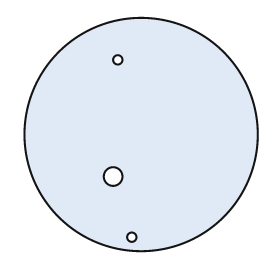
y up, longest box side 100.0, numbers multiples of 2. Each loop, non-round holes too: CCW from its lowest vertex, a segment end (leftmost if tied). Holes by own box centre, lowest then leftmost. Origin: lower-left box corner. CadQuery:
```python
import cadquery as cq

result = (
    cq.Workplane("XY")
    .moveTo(50.0, 50.0)
    .circle(50.0)
    .moveTo(46.0, 6.0)
    .circle(2.0)
    .moveTo(38.0, 32.0)
    .circle(4.0)
    .moveTo(40.0, 82.0)
    .circle(2.0)
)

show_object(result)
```